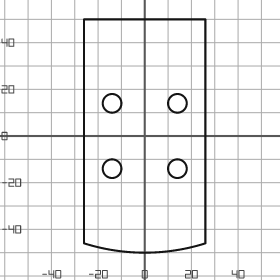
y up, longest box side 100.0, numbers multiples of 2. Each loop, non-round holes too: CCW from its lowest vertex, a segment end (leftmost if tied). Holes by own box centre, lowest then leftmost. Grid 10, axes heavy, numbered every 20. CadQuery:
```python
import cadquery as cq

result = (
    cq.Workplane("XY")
    .moveTo(-26.0, -46.0)
    .threePointArc((0.0, -50.0), (26.0, -46.0))
    .lineTo(26.0, 50.0)
    .lineTo(-26.0, 50.0)
    .close()
    .moveTo(-14.0, -14.0)
    .circle(4.0)
    .moveTo(14.0, -14.0)
    .circle(4.0)
    .moveTo(-14.0, 14.0)
    .circle(4.0)
    .moveTo(14.0, 14.0)
    .circle(4.0)
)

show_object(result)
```